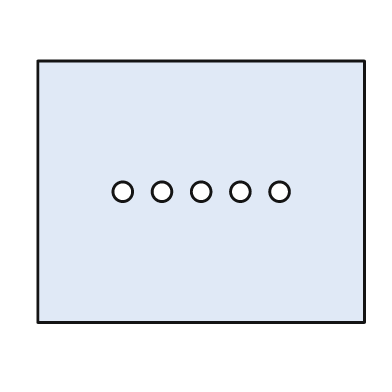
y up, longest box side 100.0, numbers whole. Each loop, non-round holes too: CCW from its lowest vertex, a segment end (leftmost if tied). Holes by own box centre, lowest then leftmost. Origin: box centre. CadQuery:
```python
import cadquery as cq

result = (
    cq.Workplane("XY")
    .moveTo(-50.0, -40.0)
    .lineTo(50.0, -40.0)
    .lineTo(50.0, 40.0)
    .lineTo(-50.0, 40.0)
    .close()
    .moveTo(-24.0, 0.0)
    .circle(3.0)
    .moveTo(-12.0, 0.0)
    .circle(3.0)
    .moveTo(0.0, 0.0)
    .circle(3.0)
    .moveTo(12.0, 0.0)
    .circle(3.0)
    .moveTo(24.0, 0.0)
    .circle(3.0)
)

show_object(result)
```